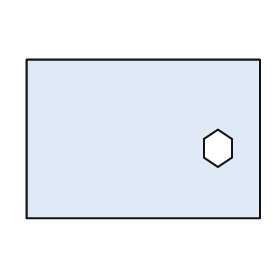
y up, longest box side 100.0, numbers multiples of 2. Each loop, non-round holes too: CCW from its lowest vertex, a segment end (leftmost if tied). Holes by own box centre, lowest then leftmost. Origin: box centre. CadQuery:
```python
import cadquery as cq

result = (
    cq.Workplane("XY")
    .moveTo(-50.0, -34.0)
    .lineTo(50.0, -34.0)
    .lineTo(50.0, 34.0)
    .lineTo(-50.0, 34.0)
    .close()
    .moveTo(32.0, -12.0)
    .lineTo(38.0, -8.0)
    .lineTo(38.0, 0.0)
    .lineTo(32.0, 4.0)
    .lineTo(26.0, 0.0)
    .lineTo(26.0, -8.0)
    .close()
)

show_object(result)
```